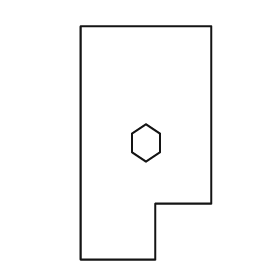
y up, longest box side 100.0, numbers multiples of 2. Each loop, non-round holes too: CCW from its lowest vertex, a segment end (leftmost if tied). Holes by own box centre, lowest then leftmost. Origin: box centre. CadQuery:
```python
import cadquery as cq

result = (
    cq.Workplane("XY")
    .moveTo(-28.0, -50.0)
    .lineTo(4.0, -50.0)
    .lineTo(4.0, -26.0)
    .lineTo(28.0, -26.0)
    .lineTo(28.0, 50.0)
    .lineTo(-28.0, 50.0)
    .close()
    .moveTo(0.0, -8.0)
    .lineTo(6.0, -4.0)
    .lineTo(6.0, 4.0)
    .lineTo(0.0, 8.0)
    .lineTo(-6.0, 4.0)
    .lineTo(-6.0, -4.0)
    .close()
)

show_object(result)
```